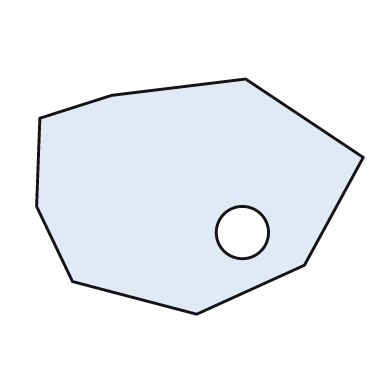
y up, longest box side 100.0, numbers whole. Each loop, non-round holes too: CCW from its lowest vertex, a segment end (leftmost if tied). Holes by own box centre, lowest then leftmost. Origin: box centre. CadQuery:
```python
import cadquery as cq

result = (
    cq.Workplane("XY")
    .moveTo(-1.0, -36.0)
    .lineTo(32.0, -21.0)
    .lineTo(50.0, 12.0)
    .lineTo(14.0, 36.0)
    .lineTo(-27.0, 31.0)
    .lineTo(-49.0, 24.0)
    .lineTo(-50.0, -3.0)
    .lineTo(-39.0, -26.0)
    .close()
    .moveTo(13.0, -11.0)
    .circle(8.0)
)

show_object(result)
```